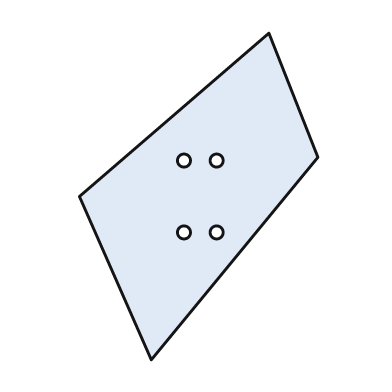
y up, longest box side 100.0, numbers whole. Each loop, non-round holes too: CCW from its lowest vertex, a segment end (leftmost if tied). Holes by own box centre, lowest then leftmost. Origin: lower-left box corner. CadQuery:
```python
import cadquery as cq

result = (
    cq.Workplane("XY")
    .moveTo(22.0, 0.0)
    .lineTo(73.0, 62.0)
    .lineTo(58.0, 100.0)
    .lineTo(0.0, 50.0)
    .close()
    .moveTo(32.0, 39.0)
    .circle(2.0)
    .moveTo(42.0, 39.0)
    .circle(2.0)
    .moveTo(32.0, 61.0)
    .circle(2.0)
    .moveTo(42.0, 61.0)
    .circle(2.0)
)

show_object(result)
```